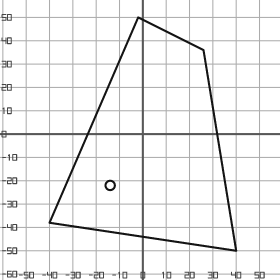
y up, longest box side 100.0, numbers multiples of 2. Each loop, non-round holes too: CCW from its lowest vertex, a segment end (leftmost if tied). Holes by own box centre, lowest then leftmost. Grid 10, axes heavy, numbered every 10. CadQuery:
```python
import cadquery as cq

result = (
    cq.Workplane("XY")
    .moveTo(40.0, -50.0)
    .lineTo(26.0, 36.0)
    .lineTo(-2.0, 50.0)
    .lineTo(-40.0, -38.0)
    .close()
    .moveTo(-14.0, -22.0)
    .circle(2.0)
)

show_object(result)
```